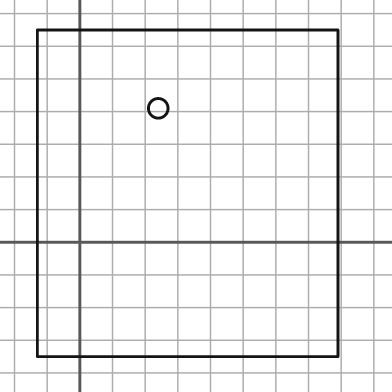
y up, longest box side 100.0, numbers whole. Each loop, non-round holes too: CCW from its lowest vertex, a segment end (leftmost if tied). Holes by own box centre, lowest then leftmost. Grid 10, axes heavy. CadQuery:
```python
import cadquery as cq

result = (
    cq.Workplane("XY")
    .moveTo(-13.0, -35.0)
    .lineTo(79.0, -35.0)
    .lineTo(79.0, 65.0)
    .lineTo(-13.0, 65.0)
    .close()
    .moveTo(24.0, 41.0)
    .circle(3.0)
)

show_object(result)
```